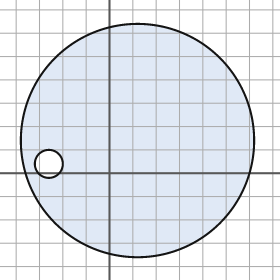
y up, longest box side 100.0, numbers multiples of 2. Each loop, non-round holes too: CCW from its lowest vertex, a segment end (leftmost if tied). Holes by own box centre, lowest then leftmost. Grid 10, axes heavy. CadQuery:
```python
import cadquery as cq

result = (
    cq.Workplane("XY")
    .moveTo(12.0, 14.0)
    .circle(50.0)
    .moveTo(-26.0, 4.0)
    .circle(6.0)
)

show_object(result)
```